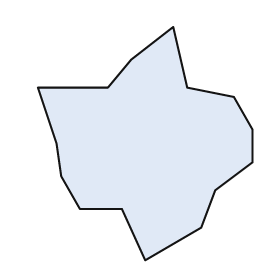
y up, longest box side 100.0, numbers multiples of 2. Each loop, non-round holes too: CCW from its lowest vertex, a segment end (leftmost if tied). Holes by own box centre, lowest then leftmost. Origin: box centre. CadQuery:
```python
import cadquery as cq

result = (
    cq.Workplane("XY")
    .moveTo(0.0, -50.0)
    .lineTo(24.0, -36.0)
    .lineTo(30.0, -20.0)
    .lineTo(46.0, -8.0)
    .lineTo(46.0, 6.0)
    .lineTo(38.0, 20.0)
    .lineTo(18.0, 24.0)
    .lineTo(12.0, 50.0)
    .lineTo(-6.0, 36.0)
    .lineTo(-16.0, 24.0)
    .lineTo(-46.0, 24.0)
    .lineTo(-38.0, 0.0)
    .lineTo(-36.0, -14.0)
    .lineTo(-28.0, -28.0)
    .lineTo(-10.0, -28.0)
    .close()
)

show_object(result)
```